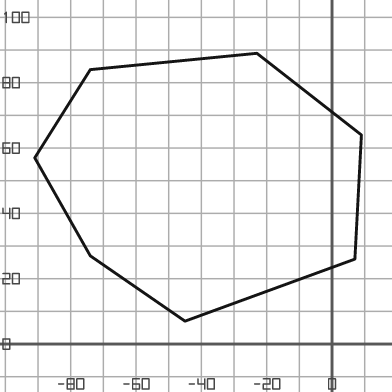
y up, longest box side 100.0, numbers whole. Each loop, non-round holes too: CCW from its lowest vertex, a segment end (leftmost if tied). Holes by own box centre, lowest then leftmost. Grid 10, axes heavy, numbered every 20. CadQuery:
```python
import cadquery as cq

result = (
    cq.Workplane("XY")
    .moveTo(-45.0, 7.0)
    .lineTo(7.0, 26.0)
    .lineTo(9.0, 64.0)
    .lineTo(-23.0, 89.0)
    .lineTo(-74.0, 84.0)
    .lineTo(-91.0, 57.0)
    .lineTo(-74.0, 27.0)
    .close()
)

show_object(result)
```